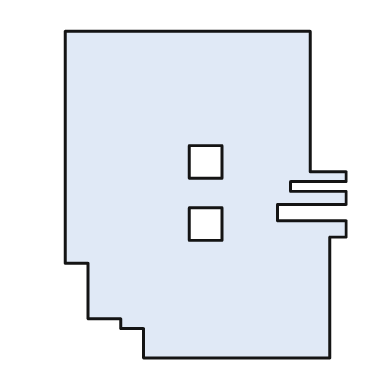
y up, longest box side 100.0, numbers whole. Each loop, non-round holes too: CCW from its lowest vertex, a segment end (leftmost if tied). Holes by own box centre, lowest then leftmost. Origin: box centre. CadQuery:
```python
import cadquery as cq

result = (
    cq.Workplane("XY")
    .moveTo(-19.0, -50.0)
    .lineTo(38.0, -50.0)
    .lineTo(38.0, -13.0)
    .lineTo(43.0, -13.0)
    .lineTo(43.0, -8.0)
    .lineTo(22.0, -8.0)
    .lineTo(22.0, -3.0)
    .lineTo(43.0, -3.0)
    .lineTo(43.0, 1.0)
    .lineTo(26.0, 1.0)
    .lineTo(26.0, 4.0)
    .lineTo(43.0, 4.0)
    .lineTo(43.0, 7.0)
    .lineTo(32.0, 7.0)
    .lineTo(32.0, 50.0)
    .lineTo(-43.0, 50.0)
    .lineTo(-43.0, -21.0)
    .lineTo(-36.0, -21.0)
    .lineTo(-36.0, -38.0)
    .lineTo(-26.0, -38.0)
    .lineTo(-26.0, -41.0)
    .lineTo(-19.0, -41.0)
    .close()
    .moveTo(-5.0, -14.0)
    .lineTo(5.0, -14.0)
    .lineTo(5.0, -4.0)
    .lineTo(-5.0, -4.0)
    .close()
    .moveTo(-5.0, 5.0)
    .lineTo(5.0, 5.0)
    .lineTo(5.0, 15.0)
    .lineTo(-5.0, 15.0)
    .close()
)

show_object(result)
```